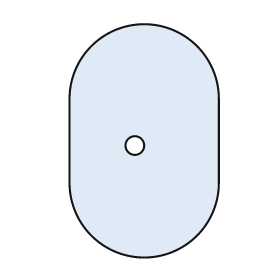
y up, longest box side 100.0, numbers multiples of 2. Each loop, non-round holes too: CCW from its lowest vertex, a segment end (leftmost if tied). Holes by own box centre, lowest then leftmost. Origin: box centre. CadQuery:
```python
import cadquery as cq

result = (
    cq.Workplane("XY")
    .moveTo(-32.0, -18.0)
    .threePointArc((0.0, -50.0), (32.0, -18.0))
    .lineTo(32.0, 18.0)
    .threePointArc((0.0, 50.0), (-32.0, 18.0))
    .close()
    .moveTo(-4.0, -2.0)
    .circle(4.0)
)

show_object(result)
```